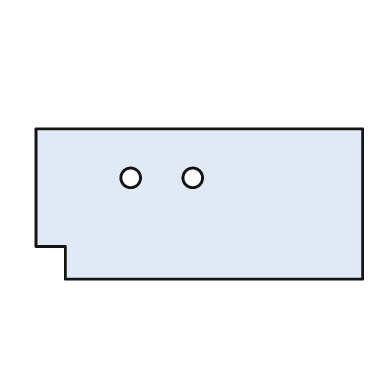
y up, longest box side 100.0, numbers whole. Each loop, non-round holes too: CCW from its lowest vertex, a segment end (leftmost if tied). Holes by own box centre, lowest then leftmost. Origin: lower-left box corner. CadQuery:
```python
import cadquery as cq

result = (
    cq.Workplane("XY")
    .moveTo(9.0, 0.0)
    .lineTo(100.0, 0.0)
    .lineTo(100.0, 46.0)
    .lineTo(0.0, 46.0)
    .lineTo(0.0, 10.0)
    .lineTo(9.0, 10.0)
    .close()
    .moveTo(29.0, 31.0)
    .circle(3.0)
    .moveTo(48.0, 31.0)
    .circle(3.0)
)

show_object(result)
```